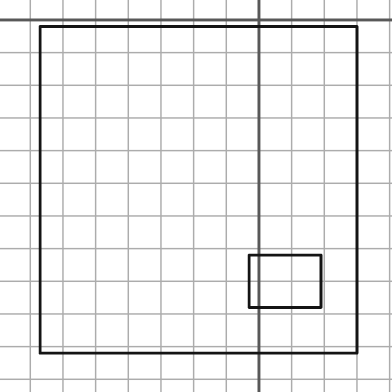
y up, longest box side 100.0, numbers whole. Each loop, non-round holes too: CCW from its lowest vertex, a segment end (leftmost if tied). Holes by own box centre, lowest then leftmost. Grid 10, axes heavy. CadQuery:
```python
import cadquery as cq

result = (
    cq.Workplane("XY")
    .moveTo(-67.0, -102.0)
    .lineTo(30.0, -102.0)
    .lineTo(30.0, -2.0)
    .lineTo(-67.0, -2.0)
    .close()
    .moveTo(-3.0, -88.0)
    .lineTo(19.0, -88.0)
    .lineTo(19.0, -72.0)
    .lineTo(-3.0, -72.0)
    .close()
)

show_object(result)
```